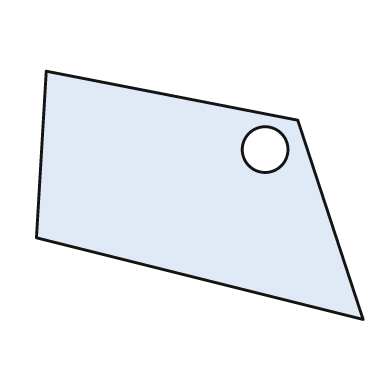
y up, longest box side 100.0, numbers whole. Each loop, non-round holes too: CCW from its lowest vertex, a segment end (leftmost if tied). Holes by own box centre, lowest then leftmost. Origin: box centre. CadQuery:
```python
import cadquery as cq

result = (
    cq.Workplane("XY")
    .moveTo(50.0, -38.0)
    .lineTo(30.0, 23.0)
    .lineTo(-47.0, 38.0)
    .lineTo(-50.0, -13.0)
    .close()
    .moveTo(20.0, 14.0)
    .circle(7.0)
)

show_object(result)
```